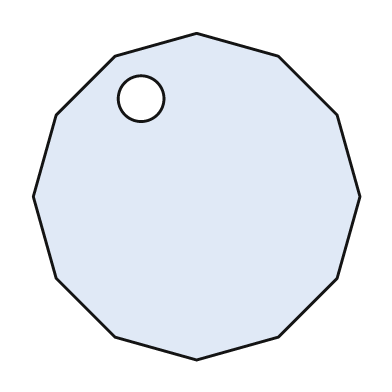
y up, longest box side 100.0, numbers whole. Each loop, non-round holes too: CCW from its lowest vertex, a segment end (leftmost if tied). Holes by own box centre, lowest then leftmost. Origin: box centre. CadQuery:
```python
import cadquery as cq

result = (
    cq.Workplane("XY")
    .moveTo(0.0, -50.0)
    .lineTo(25.0, -43.0)
    .lineTo(43.0, -25.0)
    .lineTo(50.0, 0.0)
    .lineTo(43.0, 25.0)
    .lineTo(25.0, 43.0)
    .lineTo(0.0, 50.0)
    .lineTo(-25.0, 43.0)
    .lineTo(-43.0, 25.0)
    .lineTo(-50.0, 0.0)
    .lineTo(-43.0, -25.0)
    .lineTo(-25.0, -43.0)
    .close()
    .moveTo(-17.0, 30.0)
    .circle(7.0)
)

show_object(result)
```